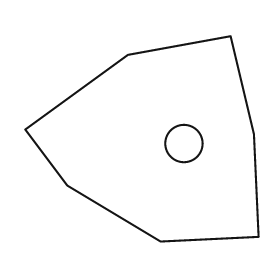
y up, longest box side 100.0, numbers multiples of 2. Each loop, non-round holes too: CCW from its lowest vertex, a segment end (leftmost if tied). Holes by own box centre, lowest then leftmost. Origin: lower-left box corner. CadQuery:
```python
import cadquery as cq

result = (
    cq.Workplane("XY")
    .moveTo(58.0, 0.0)
    .lineTo(100.0, 2.0)
    .lineTo(98.0, 46.0)
    .lineTo(88.0, 88.0)
    .lineTo(44.0, 80.0)
    .lineTo(0.0, 48.0)
    .lineTo(18.0, 24.0)
    .close()
    .moveTo(68.0, 42.0)
    .circle(8.0)
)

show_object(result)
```